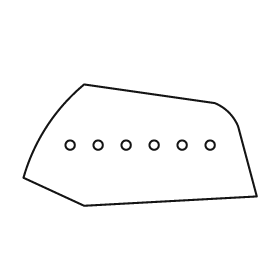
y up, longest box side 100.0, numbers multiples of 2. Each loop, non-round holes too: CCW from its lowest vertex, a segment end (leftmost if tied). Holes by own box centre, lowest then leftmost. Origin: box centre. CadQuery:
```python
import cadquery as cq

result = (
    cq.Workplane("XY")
    .moveTo(-24.0, -26.0)
    .lineTo(50.0, -22.0)
    .lineTo(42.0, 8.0)
    .threePointArc((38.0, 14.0), (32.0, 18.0))
    .lineTo(-24.0, 26.0)
    .threePointArc((-40.0, 8.0), (-50.0, -14.0))
    .close()
    .moveTo(-30.0, 0.0)
    .circle(2.0)
    .moveTo(-18.0, 0.0)
    .circle(2.0)
    .moveTo(-6.0, 0.0)
    .circle(2.0)
    .moveTo(6.0, 0.0)
    .circle(2.0)
    .moveTo(18.0, 0.0)
    .circle(2.0)
    .moveTo(30.0, 0.0)
    .circle(2.0)
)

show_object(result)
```